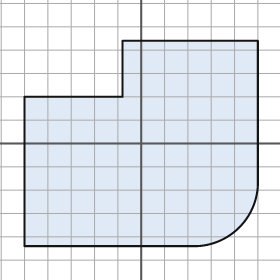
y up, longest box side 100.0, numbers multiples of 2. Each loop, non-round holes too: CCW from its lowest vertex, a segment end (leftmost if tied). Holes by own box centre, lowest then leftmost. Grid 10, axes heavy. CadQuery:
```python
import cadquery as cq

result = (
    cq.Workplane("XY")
    .moveTo(-50.0, -44.0)
    .lineTo(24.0, -44.0)
    .threePointArc((42.0, -36.0), (50.0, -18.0))
    .lineTo(50.0, 44.0)
    .lineTo(-8.0, 44.0)
    .lineTo(-8.0, 20.0)
    .lineTo(-50.0, 20.0)
    .close()
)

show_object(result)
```